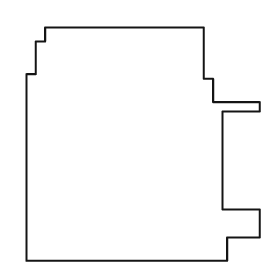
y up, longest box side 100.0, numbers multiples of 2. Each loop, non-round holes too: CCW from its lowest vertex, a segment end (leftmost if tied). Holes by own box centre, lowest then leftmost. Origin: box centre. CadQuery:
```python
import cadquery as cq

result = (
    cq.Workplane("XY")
    .moveTo(-50.0, -50.0)
    .lineTo(36.0, -50.0)
    .lineTo(36.0, -40.0)
    .lineTo(50.0, -40.0)
    .lineTo(50.0, -28.0)
    .lineTo(34.0, -28.0)
    .lineTo(34.0, 14.0)
    .lineTo(50.0, 14.0)
    .lineTo(50.0, 18.0)
    .lineTo(30.0, 18.0)
    .lineTo(30.0, 28.0)
    .lineTo(26.0, 28.0)
    .lineTo(26.0, 50.0)
    .lineTo(-42.0, 50.0)
    .lineTo(-42.0, 44.0)
    .lineTo(-46.0, 44.0)
    .lineTo(-46.0, 30.0)
    .lineTo(-50.0, 30.0)
    .close()
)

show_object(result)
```